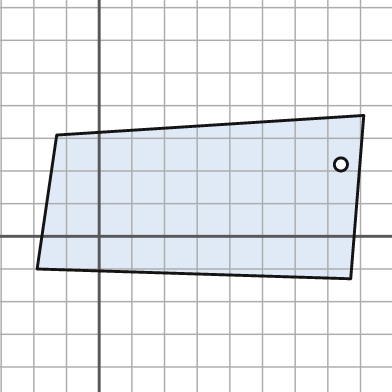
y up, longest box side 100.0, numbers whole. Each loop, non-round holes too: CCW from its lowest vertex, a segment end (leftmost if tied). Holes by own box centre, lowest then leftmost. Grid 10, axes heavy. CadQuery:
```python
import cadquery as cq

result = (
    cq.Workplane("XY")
    .moveTo(77.0, -13.0)
    .lineTo(81.0, 37.0)
    .lineTo(-13.0, 31.0)
    .lineTo(-19.0, -10.0)
    .close()
    .moveTo(74.0, 22.0)
    .circle(2.0)
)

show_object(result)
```